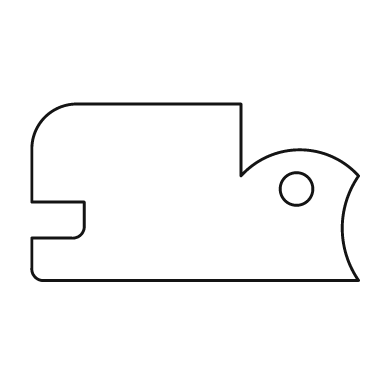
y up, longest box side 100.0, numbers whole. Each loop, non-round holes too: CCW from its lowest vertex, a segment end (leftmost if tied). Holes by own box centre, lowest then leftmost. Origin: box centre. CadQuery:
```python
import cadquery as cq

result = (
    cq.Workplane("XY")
    .moveTo(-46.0, -27.0)
    .lineTo(50.0, -27.0)
    .threePointArc((45.0, -11.0), (50.0, 5.0))
    .threePointArc((32.0, 13.0), (14.0, 5.0))
    .lineTo(14.0, 27.0)
    .lineTo(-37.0, 27.0)
    .threePointArc((-46.0, 23.0), (-50.0, 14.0))
    .lineTo(-50.0, -3.0)
    .lineTo(-34.0, -3.0)
    .lineTo(-34.0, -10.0)
    .threePointArc((-35.0, -13.0), (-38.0, -14.0))
    .lineTo(-50.0, -14.0)
    .lineTo(-50.0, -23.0)
    .threePointArc((-49.0, -26.0), (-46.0, -27.0))
    .close()
    .moveTo(31.0, 1.0)
    .circle(5.0)
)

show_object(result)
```